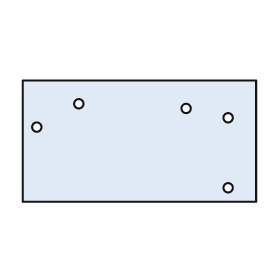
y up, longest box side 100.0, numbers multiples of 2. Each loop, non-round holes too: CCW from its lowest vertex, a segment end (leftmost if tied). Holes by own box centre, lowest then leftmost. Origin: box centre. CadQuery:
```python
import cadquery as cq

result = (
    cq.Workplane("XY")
    .moveTo(-50.0, -26.0)
    .lineTo(50.0, -26.0)
    .lineTo(50.0, 26.0)
    .lineTo(-50.0, 26.0)
    .close()
    .moveTo(38.0, -20.0)
    .circle(2.0)
    .moveTo(-44.0, 6.0)
    .circle(2.0)
    .moveTo(38.0, 10.0)
    .circle(2.0)
    .moveTo(20.0, 14.0)
    .circle(2.0)
    .moveTo(-26.0, 16.0)
    .circle(2.0)
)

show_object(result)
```